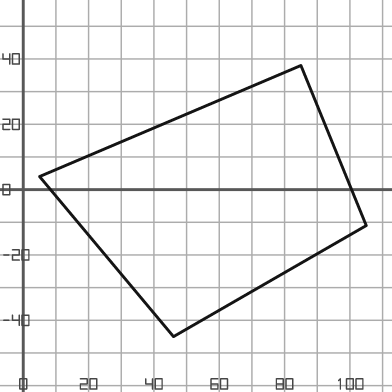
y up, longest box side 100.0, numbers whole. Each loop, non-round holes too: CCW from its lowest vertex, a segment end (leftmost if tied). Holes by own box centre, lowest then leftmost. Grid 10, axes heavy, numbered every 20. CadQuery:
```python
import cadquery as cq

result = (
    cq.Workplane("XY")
    .moveTo(46.0, -45.0)
    .lineTo(105.0, -11.0)
    .lineTo(85.0, 38.0)
    .lineTo(5.0, 4.0)
    .close()
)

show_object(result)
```